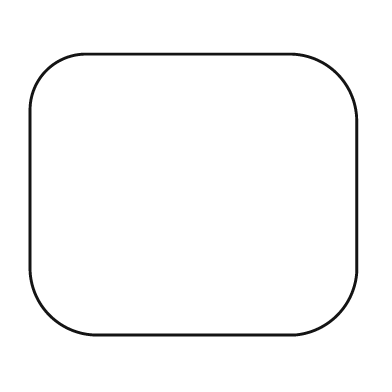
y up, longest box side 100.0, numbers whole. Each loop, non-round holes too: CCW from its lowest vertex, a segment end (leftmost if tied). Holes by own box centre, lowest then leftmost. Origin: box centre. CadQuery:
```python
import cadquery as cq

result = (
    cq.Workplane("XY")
    .moveTo(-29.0, -43.0)
    .lineTo(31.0, -43.0)
    .threePointArc((44.0, -37.0), (50.0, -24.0))
    .lineTo(50.0, 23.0)
    .threePointArc((44.0, 37.0), (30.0, 43.0))
    .lineTo(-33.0, 43.0)
    .threePointArc((-45.0, 38.0), (-50.0, 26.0))
    .lineTo(-50.0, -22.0)
    .threePointArc((-44.0, -37.0), (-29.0, -43.0))
    .close()
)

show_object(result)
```